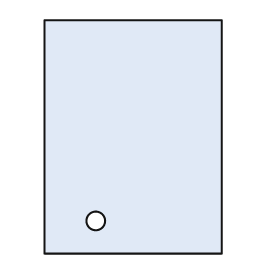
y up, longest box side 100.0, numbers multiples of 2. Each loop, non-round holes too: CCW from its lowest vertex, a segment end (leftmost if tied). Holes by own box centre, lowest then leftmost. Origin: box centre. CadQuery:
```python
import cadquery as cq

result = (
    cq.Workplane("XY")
    .moveTo(-38.0, -50.0)
    .lineTo(38.0, -50.0)
    .lineTo(38.0, 50.0)
    .lineTo(-38.0, 50.0)
    .close()
    .moveTo(-16.0, -36.0)
    .circle(4.0)
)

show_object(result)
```